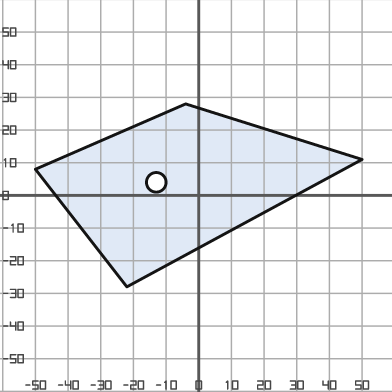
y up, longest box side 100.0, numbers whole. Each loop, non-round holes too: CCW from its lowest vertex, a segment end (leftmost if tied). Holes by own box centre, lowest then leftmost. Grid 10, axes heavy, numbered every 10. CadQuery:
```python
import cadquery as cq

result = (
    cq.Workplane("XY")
    .moveTo(-22.0, -28.0)
    .lineTo(50.0, 11.0)
    .lineTo(-4.0, 28.0)
    .lineTo(-50.0, 8.0)
    .close()
    .moveTo(-13.0, 4.0)
    .circle(3.0)
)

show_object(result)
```